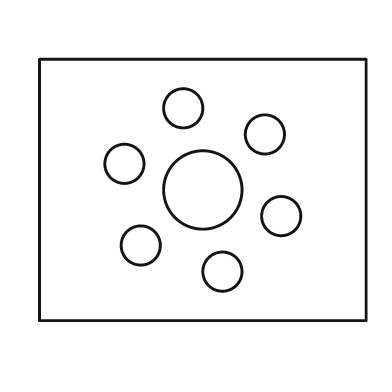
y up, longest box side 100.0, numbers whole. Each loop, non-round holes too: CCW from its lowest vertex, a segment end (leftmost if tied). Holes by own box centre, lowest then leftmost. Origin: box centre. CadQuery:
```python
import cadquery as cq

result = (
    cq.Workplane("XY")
    .moveTo(-50.0, -40.0)
    .lineTo(50.0, -40.0)
    .lineTo(50.0, 40.0)
    .lineTo(-50.0, 40.0)
    .close()
    .moveTo(6.0, -25.0)
    .circle(6.0)
    .moveTo(-19.0, -17.0)
    .circle(6.0)
    .moveTo(24.0, -8.0)
    .circle(6.0)
    .moveTo(0.0, 0.0)
    .circle(12.0)
    .moveTo(-24.0, 8.0)
    .circle(6.0)
    .moveTo(19.0, 17.0)
    .circle(6.0)
    .moveTo(-6.0, 25.0)
    .circle(6.0)
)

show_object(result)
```